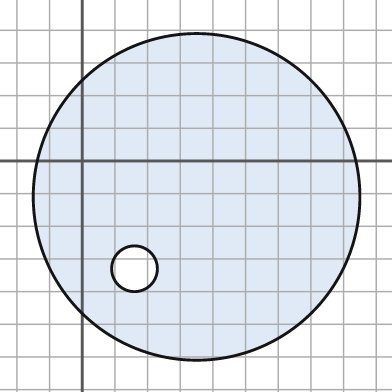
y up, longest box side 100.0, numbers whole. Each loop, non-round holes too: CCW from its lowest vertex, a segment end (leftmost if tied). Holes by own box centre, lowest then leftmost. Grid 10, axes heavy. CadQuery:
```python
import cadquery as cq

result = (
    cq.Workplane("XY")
    .moveTo(35.0, -11.0)
    .circle(50.0)
    .moveTo(16.0, -33.0)
    .circle(7.0)
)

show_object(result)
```